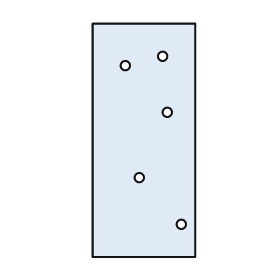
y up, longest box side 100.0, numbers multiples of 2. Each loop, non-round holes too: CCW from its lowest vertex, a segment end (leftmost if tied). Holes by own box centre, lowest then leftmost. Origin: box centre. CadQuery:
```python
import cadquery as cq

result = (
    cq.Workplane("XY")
    .moveTo(-22.0, -50.0)
    .lineTo(22.0, -50.0)
    .lineTo(22.0, 50.0)
    .lineTo(-22.0, 50.0)
    .close()
    .moveTo(16.0, -36.0)
    .circle(2.0)
    .moveTo(-2.0, -16.0)
    .circle(2.0)
    .moveTo(10.0, 12.0)
    .circle(2.0)
    .moveTo(-8.0, 32.0)
    .circle(2.0)
    .moveTo(8.0, 36.0)
    .circle(2.0)
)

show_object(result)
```